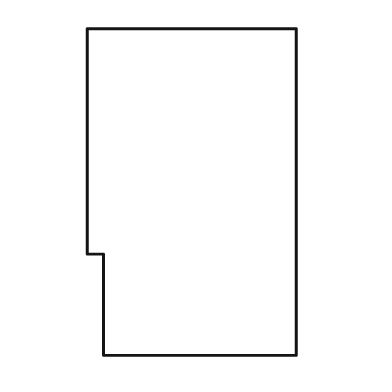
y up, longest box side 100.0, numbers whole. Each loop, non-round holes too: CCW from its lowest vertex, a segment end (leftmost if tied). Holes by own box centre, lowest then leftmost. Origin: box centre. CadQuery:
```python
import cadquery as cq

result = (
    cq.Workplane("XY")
    .moveTo(-27.0, -50.0)
    .lineTo(32.0, -50.0)
    .lineTo(32.0, 50.0)
    .lineTo(-32.0, 50.0)
    .lineTo(-32.0, -19.0)
    .lineTo(-27.0, -19.0)
    .close()
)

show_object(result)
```